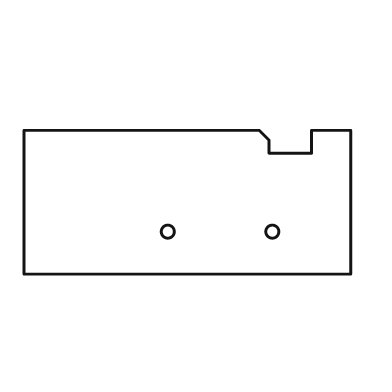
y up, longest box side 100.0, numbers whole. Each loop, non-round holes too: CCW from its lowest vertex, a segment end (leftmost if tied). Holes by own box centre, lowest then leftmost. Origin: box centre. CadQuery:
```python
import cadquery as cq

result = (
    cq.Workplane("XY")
    .moveTo(-50.0, -22.0)
    .lineTo(50.0, -22.0)
    .lineTo(50.0, 22.0)
    .lineTo(38.0, 22.0)
    .lineTo(38.0, 15.0)
    .lineTo(25.0, 15.0)
    .lineTo(25.0, 19.0)
    .lineTo(22.0, 22.0)
    .lineTo(-50.0, 22.0)
    .close()
    .moveTo(-6.0, -9.0)
    .circle(2.0)
    .moveTo(26.0, -9.0)
    .circle(2.0)
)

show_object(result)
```